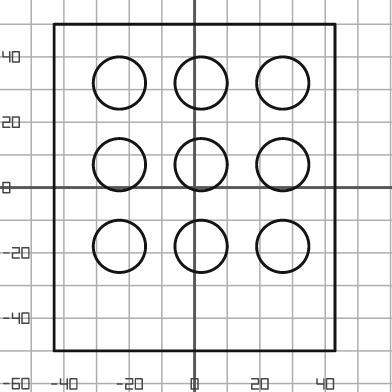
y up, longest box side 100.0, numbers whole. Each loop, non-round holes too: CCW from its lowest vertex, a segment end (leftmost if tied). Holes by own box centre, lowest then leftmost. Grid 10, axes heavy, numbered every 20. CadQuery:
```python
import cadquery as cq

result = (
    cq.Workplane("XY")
    .moveTo(-43.0, -50.0)
    .lineTo(43.0, -50.0)
    .lineTo(43.0, 50.0)
    .lineTo(-43.0, 50.0)
    .close()
    .moveTo(-23.0, -18.0)
    .circle(8.0)
    .moveTo(2.0, -18.0)
    .circle(8.0)
    .moveTo(27.0, -18.0)
    .circle(8.0)
    .moveTo(-23.0, 7.0)
    .circle(8.0)
    .moveTo(2.0, 7.0)
    .circle(8.0)
    .moveTo(27.0, 7.0)
    .circle(8.0)
    .moveTo(-23.0, 32.0)
    .circle(8.0)
    .moveTo(2.0, 32.0)
    .circle(8.0)
    .moveTo(27.0, 32.0)
    .circle(8.0)
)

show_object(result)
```